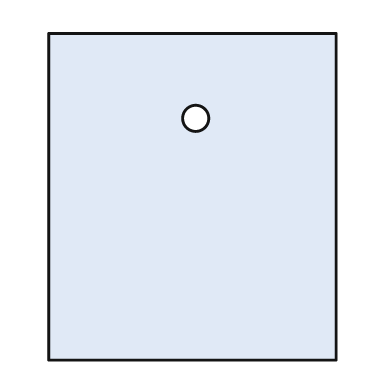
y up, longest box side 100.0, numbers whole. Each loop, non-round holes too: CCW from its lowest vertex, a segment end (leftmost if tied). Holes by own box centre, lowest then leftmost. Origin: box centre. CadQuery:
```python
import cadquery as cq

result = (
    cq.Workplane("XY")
    .moveTo(-44.0, -50.0)
    .lineTo(44.0, -50.0)
    .lineTo(44.0, 50.0)
    .lineTo(-44.0, 50.0)
    .close()
    .moveTo(1.0, 24.0)
    .circle(4.0)
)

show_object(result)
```